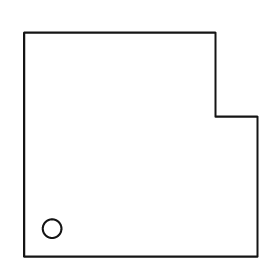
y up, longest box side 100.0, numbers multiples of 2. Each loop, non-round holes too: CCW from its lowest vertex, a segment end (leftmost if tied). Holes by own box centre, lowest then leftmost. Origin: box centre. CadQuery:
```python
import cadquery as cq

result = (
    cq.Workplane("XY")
    .moveTo(-50.0, -48.0)
    .lineTo(50.0, -48.0)
    .lineTo(50.0, 12.0)
    .lineTo(32.0, 12.0)
    .lineTo(32.0, 48.0)
    .lineTo(-50.0, 48.0)
    .close()
    .moveTo(-38.0, -36.0)
    .circle(4.0)
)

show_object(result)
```